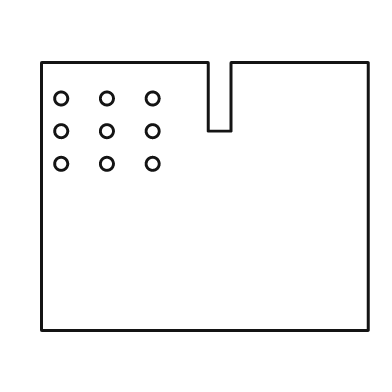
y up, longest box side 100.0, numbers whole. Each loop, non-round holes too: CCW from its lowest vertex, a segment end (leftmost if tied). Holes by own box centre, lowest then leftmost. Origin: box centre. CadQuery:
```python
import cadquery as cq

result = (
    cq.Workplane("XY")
    .moveTo(-50.0, -41.0)
    .lineTo(50.0, -41.0)
    .lineTo(50.0, 41.0)
    .lineTo(8.0, 41.0)
    .lineTo(8.0, 20.0)
    .lineTo(1.0, 20.0)
    .lineTo(1.0, 41.0)
    .lineTo(-50.0, 41.0)
    .close()
    .moveTo(-44.0, 10.0)
    .circle(2.0)
    .moveTo(-30.0, 10.0)
    .circle(2.0)
    .moveTo(-16.0, 10.0)
    .circle(2.0)
    .moveTo(-44.0, 20.0)
    .circle(2.0)
    .moveTo(-30.0, 20.0)
    .circle(2.0)
    .moveTo(-16.0, 20.0)
    .circle(2.0)
    .moveTo(-44.0, 30.0)
    .circle(2.0)
    .moveTo(-30.0, 30.0)
    .circle(2.0)
    .moveTo(-16.0, 30.0)
    .circle(2.0)
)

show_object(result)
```